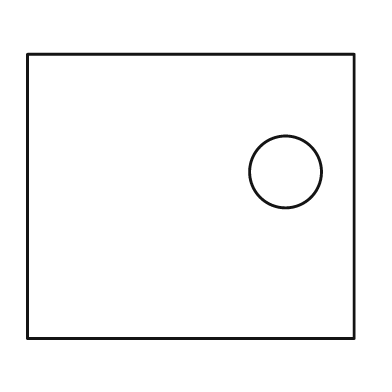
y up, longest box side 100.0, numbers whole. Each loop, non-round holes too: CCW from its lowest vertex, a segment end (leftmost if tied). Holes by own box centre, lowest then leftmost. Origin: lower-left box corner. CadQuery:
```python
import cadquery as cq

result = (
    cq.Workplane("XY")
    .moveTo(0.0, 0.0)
    .lineTo(100.0, 0.0)
    .lineTo(100.0, 87.0)
    .lineTo(0.0, 87.0)
    .close()
    .moveTo(79.0, 51.0)
    .circle(11.0)
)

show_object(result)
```